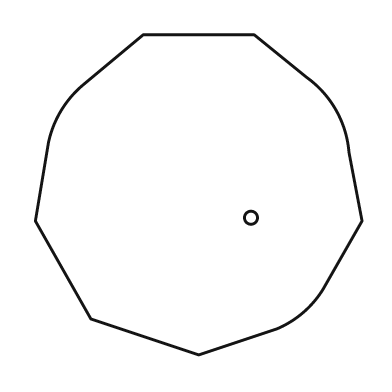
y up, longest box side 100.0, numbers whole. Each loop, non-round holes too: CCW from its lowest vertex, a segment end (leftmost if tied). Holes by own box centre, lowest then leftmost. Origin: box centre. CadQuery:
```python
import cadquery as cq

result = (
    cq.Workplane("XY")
    .moveTo(0.0, -49.0)
    .lineTo(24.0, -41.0)
    .threePointArc((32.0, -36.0), (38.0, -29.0))
    .lineTo(50.0, -8.0)
    .lineTo(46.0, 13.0)
    .threePointArc((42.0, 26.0), (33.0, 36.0))
    .lineTo(17.0, 49.0)
    .lineTo(-17.0, 49.0)
    .lineTo(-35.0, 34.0)
    .threePointArc((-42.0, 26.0), (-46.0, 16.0))
    .lineTo(-50.0, -8.0)
    .lineTo(-33.0, -38.0)
    .close()
    .moveTo(16.0, -7.0)
    .circle(2.0)
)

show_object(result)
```